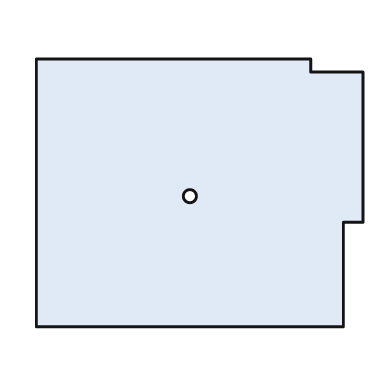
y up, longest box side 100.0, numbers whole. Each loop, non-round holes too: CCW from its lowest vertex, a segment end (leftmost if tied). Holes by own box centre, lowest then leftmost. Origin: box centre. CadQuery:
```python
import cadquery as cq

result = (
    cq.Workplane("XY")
    .moveTo(-50.0, -41.0)
    .lineTo(44.0, -41.0)
    .lineTo(44.0, -9.0)
    .lineTo(50.0, -9.0)
    .lineTo(50.0, 37.0)
    .lineTo(34.0, 37.0)
    .lineTo(34.0, 41.0)
    .lineTo(-50.0, 41.0)
    .close()
    .moveTo(-3.0, -1.0)
    .circle(2.0)
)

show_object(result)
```